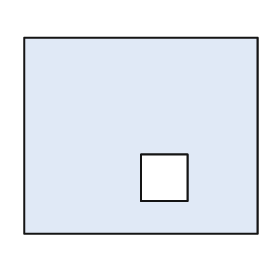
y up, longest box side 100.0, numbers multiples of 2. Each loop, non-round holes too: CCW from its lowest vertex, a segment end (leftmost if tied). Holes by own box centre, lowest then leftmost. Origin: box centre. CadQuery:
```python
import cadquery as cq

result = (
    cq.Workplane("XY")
    .moveTo(-50.0, -42.0)
    .lineTo(50.0, -42.0)
    .lineTo(50.0, 42.0)
    .lineTo(-50.0, 42.0)
    .close()
    .moveTo(0.0, -28.0)
    .lineTo(20.0, -28.0)
    .lineTo(20.0, -8.0)
    .lineTo(0.0, -8.0)
    .close()
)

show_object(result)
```